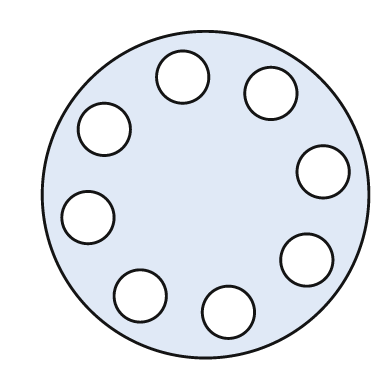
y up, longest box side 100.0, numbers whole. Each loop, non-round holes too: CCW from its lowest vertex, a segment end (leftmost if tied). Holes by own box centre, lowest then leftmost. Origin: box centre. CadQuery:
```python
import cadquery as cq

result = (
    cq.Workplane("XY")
    .moveTo(0.0, 0.0)
    .circle(50.0)
    .moveTo(7.0, -36.0)
    .circle(8.0)
    .moveTo(-20.0, -31.0)
    .circle(8.0)
    .moveTo(31.0, -20.0)
    .circle(8.0)
    .moveTo(-36.0, -7.0)
    .circle(8.0)
    .moveTo(36.0, 7.0)
    .circle(8.0)
    .moveTo(-31.0, 20.0)
    .circle(8.0)
    .moveTo(20.0, 31.0)
    .circle(8.0)
    .moveTo(-7.0, 36.0)
    .circle(8.0)
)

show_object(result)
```